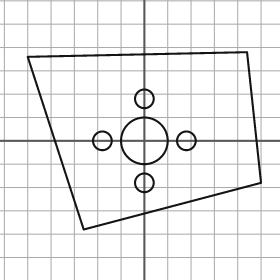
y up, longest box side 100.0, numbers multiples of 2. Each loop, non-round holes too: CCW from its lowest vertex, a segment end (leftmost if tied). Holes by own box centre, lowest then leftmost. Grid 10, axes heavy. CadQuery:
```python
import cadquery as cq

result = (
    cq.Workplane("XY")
    .moveTo(-26.0, -38.0)
    .lineTo(50.0, -18.0)
    .lineTo(44.0, 38.0)
    .lineTo(-50.0, 36.0)
    .close()
    .moveTo(0.0, -18.0)
    .circle(4.0)
    .moveTo(-18.0, 0.0)
    .circle(4.0)
    .moveTo(0.0, 0.0)
    .circle(10.0)
    .moveTo(18.0, 0.0)
    .circle(4.0)
    .moveTo(0.0, 18.0)
    .circle(4.0)
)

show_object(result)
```